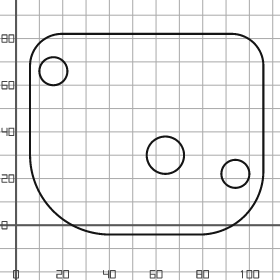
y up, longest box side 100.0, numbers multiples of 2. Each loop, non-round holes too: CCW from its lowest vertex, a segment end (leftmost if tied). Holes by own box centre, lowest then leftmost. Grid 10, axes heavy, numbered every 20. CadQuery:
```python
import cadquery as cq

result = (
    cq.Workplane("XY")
    .moveTo(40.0, -4.0)
    .lineTo(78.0, -4.0)
    .threePointArc((98.0, 4.0), (106.0, 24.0))
    .lineTo(106.0, 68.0)
    .threePointArc((102.0, 78.0), (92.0, 82.0))
    .lineTo(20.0, 82.0)
    .threePointArc((10.0, 78.0), (6.0, 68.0))
    .lineTo(6.0, 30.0)
    .threePointArc((16.0, 6.0), (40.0, -4.0))
    .close()
    .moveTo(94.0, 22.0)
    .circle(6.0)
    .moveTo(64.0, 30.0)
    .circle(8.0)
    .moveTo(16.0, 66.0)
    .circle(6.0)
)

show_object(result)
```